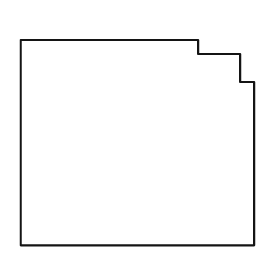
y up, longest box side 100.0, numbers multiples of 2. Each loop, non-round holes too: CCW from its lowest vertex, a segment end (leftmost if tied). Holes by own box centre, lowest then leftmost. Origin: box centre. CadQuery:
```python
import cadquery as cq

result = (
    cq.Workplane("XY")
    .moveTo(-50.0, -44.0)
    .lineTo(50.0, -44.0)
    .lineTo(50.0, 26.0)
    .lineTo(44.0, 26.0)
    .lineTo(44.0, 38.0)
    .lineTo(26.0, 38.0)
    .lineTo(26.0, 44.0)
    .lineTo(-50.0, 44.0)
    .close()
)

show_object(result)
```